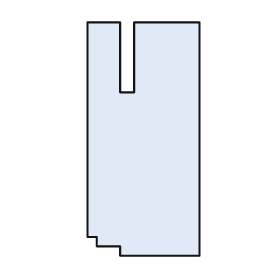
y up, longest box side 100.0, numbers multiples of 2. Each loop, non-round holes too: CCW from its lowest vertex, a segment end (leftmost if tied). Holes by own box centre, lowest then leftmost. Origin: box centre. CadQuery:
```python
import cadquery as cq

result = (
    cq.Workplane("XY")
    .moveTo(-10.0, -50.0)
    .lineTo(24.0, -50.0)
    .lineTo(24.0, 50.0)
    .lineTo(-4.0, 50.0)
    .lineTo(-4.0, 20.0)
    .lineTo(-10.0, 20.0)
    .lineTo(-10.0, 50.0)
    .lineTo(-24.0, 50.0)
    .lineTo(-24.0, -42.0)
    .lineTo(-20.0, -42.0)
    .lineTo(-20.0, -46.0)
    .lineTo(-10.0, -46.0)
    .close()
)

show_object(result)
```